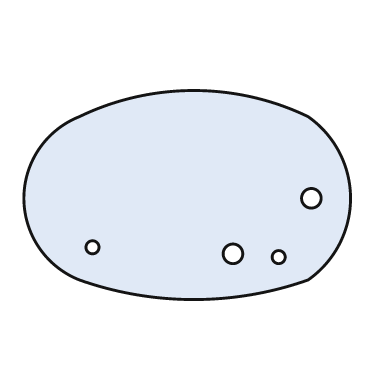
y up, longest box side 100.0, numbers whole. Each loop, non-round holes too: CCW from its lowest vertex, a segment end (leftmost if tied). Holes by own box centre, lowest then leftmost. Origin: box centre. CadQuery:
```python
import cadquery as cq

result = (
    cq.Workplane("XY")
    .moveTo(-33.0, -26.0)
    .threePointArc((2.0, -32.0), (37.0, -26.0))
    .threePointArc((50.0, -1.0), (37.0, 24.0))
    .threePointArc((2.0, 32.0), (-33.0, 24.0))
    .threePointArc((-50.0, -1.0), (-33.0, -26.0))
    .close()
    .moveTo(28.0, -19.0)
    .circle(2.0)
    .moveTo(14.0, -18.0)
    .circle(3.0)
    .moveTo(-29.0, -16.0)
    .circle(2.0)
    .moveTo(38.0, -1.0)
    .circle(3.0)
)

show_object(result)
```